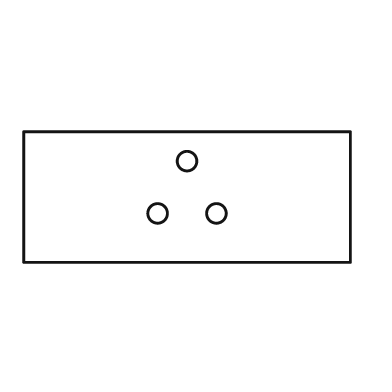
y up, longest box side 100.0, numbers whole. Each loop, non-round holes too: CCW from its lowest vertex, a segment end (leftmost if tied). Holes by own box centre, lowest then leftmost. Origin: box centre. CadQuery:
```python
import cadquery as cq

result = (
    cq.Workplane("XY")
    .moveTo(-50.0, -20.0)
    .lineTo(50.0, -20.0)
    .lineTo(50.0, 20.0)
    .lineTo(-50.0, 20.0)
    .close()
    .moveTo(-9.0, -5.0)
    .circle(3.0)
    .moveTo(9.0, -5.0)
    .circle(3.0)
    .moveTo(0.0, 11.0)
    .circle(3.0)
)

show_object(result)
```